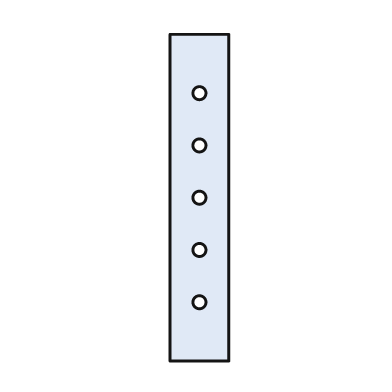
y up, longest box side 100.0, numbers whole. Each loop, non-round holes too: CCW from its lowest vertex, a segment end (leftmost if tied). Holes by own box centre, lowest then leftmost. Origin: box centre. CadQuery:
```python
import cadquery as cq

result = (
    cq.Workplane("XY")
    .moveTo(-9.0, -50.0)
    .lineTo(9.0, -50.0)
    .lineTo(9.0, 50.0)
    .lineTo(-9.0, 50.0)
    .close()
    .moveTo(0.0, -32.0)
    .circle(2.0)
    .moveTo(0.0, -16.0)
    .circle(2.0)
    .moveTo(0.0, 0.0)
    .circle(2.0)
    .moveTo(0.0, 16.0)
    .circle(2.0)
    .moveTo(0.0, 32.0)
    .circle(2.0)
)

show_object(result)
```